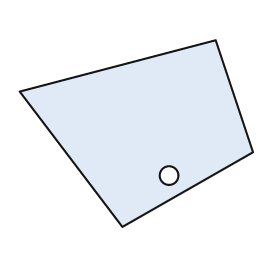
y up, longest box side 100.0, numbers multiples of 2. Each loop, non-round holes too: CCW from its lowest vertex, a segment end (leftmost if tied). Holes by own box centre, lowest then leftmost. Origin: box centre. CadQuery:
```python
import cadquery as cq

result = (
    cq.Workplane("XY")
    .moveTo(-6.0, -40.0)
    .lineTo(50.0, -8.0)
    .lineTo(34.0, 40.0)
    .lineTo(-50.0, 18.0)
    .close()
    .moveTo(14.0, -18.0)
    .circle(4.0)
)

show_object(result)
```